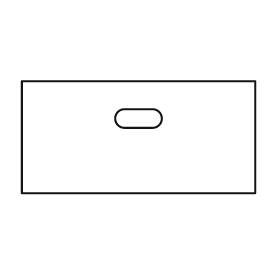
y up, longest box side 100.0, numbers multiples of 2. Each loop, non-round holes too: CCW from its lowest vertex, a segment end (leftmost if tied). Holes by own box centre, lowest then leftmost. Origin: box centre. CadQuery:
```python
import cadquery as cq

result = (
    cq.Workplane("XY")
    .moveTo(-50.0, -24.0)
    .lineTo(50.0, -24.0)
    .lineTo(50.0, 24.0)
    .lineTo(-50.0, 24.0)
    .close()
    .moveTo(-6.0, 4.0)
    .lineTo(6.0, 4.0)
    .threePointArc((10.0, 8.0), (6.0, 12.0))
    .lineTo(-6.0, 12.0)
    .threePointArc((-10.0, 8.0), (-6.0, 4.0))
    .close()
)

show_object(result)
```